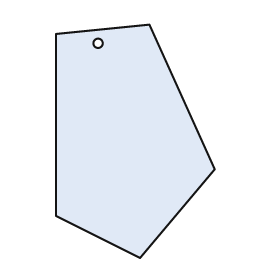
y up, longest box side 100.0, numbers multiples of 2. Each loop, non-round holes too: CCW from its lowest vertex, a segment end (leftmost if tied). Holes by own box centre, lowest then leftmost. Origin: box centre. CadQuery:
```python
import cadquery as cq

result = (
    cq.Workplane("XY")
    .moveTo(2.0, -50.0)
    .lineTo(34.0, -12.0)
    .lineTo(6.0, 50.0)
    .lineTo(-34.0, 46.0)
    .lineTo(-34.0, -32.0)
    .close()
    .moveTo(-16.0, 42.0)
    .circle(2.0)
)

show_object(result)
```